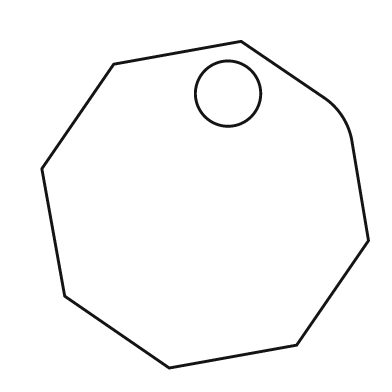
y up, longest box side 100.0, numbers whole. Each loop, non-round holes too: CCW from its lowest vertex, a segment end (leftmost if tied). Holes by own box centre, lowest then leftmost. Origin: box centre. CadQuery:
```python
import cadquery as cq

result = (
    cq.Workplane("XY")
    .moveTo(-11.0, -50.0)
    .lineTo(28.0, -43.0)
    .lineTo(50.0, -11.0)
    .lineTo(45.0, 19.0)
    .threePointArc((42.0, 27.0), (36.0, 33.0))
    .lineTo(11.0, 50.0)
    .lineTo(-28.0, 43.0)
    .lineTo(-50.0, 11.0)
    .lineTo(-43.0, -28.0)
    .close()
    .moveTo(7.0, 34.0)
    .circle(10.0)
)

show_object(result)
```